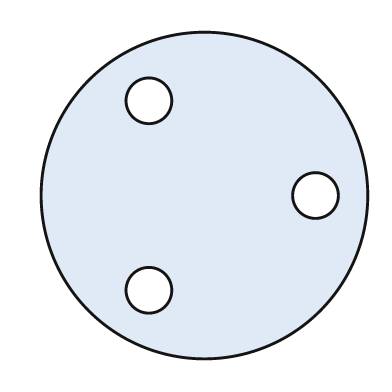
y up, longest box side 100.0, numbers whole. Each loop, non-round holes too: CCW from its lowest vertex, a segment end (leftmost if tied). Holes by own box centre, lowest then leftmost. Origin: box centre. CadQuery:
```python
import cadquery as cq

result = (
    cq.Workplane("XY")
    .moveTo(0.0, 0.0)
    .circle(50.0)
    .moveTo(-17.0, -29.0)
    .circle(7.0)
    .moveTo(34.0, 0.0)
    .circle(7.0)
    .moveTo(-17.0, 29.0)
    .circle(7.0)
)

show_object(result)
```